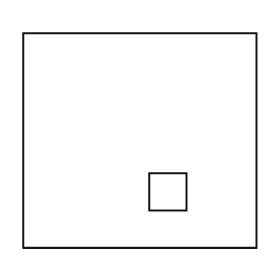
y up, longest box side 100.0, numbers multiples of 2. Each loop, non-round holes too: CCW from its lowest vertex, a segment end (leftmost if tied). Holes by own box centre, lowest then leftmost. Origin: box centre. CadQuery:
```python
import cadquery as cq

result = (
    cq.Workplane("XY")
    .moveTo(-50.0, -46.0)
    .lineTo(50.0, -46.0)
    .lineTo(50.0, 46.0)
    .lineTo(-50.0, 46.0)
    .close()
    .moveTo(4.0, -30.0)
    .lineTo(20.0, -30.0)
    .lineTo(20.0, -14.0)
    .lineTo(4.0, -14.0)
    .close()
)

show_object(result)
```